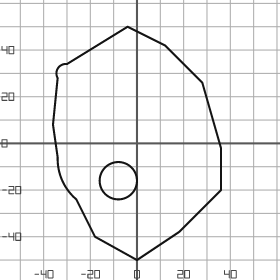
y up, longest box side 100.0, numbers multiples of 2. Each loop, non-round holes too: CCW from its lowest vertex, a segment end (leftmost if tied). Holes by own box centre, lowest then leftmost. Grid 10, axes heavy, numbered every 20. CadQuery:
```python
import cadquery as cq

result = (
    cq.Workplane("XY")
    .moveTo(0.0, -50.0)
    .lineTo(18.0, -38.0)
    .lineTo(36.0, -20.0)
    .lineTo(36.0, -2.0)
    .lineTo(28.0, 26.0)
    .lineTo(12.0, 42.0)
    .lineTo(-4.0, 50.0)
    .lineTo(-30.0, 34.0)
    .threePointArc((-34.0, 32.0), (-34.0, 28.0))
    .lineTo(-36.0, 8.0)
    .lineTo(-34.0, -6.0)
    .threePointArc((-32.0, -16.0), (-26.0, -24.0))
    .lineTo(-18.0, -40.0)
    .close()
    .moveTo(-8.0, -16.0)
    .circle(8.0)
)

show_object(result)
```